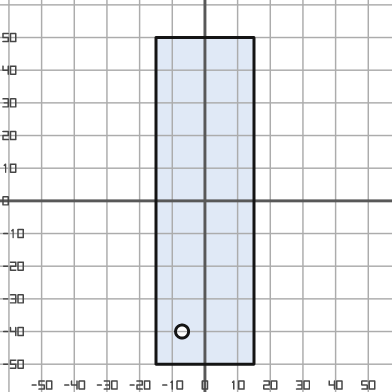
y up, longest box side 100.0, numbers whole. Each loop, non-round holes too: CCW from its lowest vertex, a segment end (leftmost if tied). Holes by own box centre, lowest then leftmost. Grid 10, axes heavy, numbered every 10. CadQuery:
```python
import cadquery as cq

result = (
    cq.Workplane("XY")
    .moveTo(-15.0, -50.0)
    .lineTo(15.0, -50.0)
    .lineTo(15.0, 50.0)
    .lineTo(-15.0, 50.0)
    .close()
    .moveTo(-7.0, -40.0)
    .circle(2.0)
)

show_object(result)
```